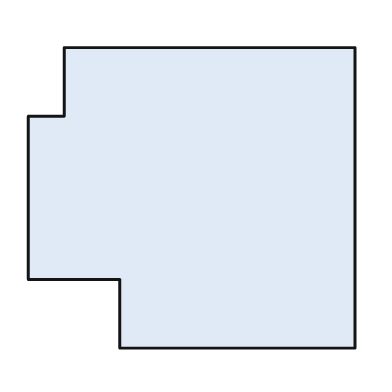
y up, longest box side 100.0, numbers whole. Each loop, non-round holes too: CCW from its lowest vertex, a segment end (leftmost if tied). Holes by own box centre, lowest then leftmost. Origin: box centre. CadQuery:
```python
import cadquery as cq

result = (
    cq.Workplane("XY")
    .moveTo(-22.0, -46.0)
    .lineTo(50.0, -46.0)
    .lineTo(50.0, 46.0)
    .lineTo(-39.0, 46.0)
    .lineTo(-39.0, 25.0)
    .lineTo(-50.0, 25.0)
    .lineTo(-50.0, -25.0)
    .lineTo(-22.0, -25.0)
    .close()
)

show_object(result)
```